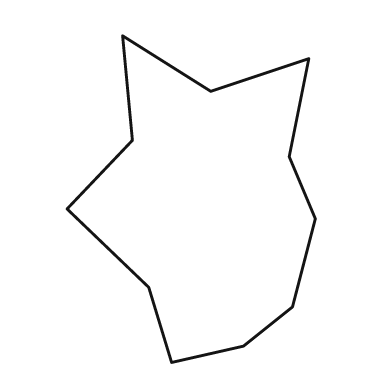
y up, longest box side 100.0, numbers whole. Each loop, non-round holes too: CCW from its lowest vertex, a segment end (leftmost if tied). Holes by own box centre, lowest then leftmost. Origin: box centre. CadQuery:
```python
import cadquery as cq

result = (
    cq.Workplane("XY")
    .moveTo(-6.0, -50.0)
    .lineTo(16.0, -45.0)
    .lineTo(31.0, -33.0)
    .lineTo(38.0, -6.0)
    .lineTo(30.0, 13.0)
    .lineTo(36.0, 43.0)
    .lineTo(6.0, 33.0)
    .lineTo(-21.0, 50.0)
    .lineTo(-18.0, 18.0)
    .lineTo(-38.0, -3.0)
    .lineTo(-13.0, -27.0)
    .close()
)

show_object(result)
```